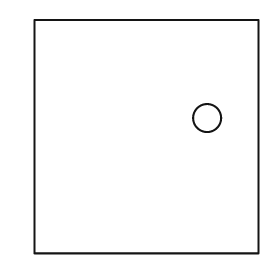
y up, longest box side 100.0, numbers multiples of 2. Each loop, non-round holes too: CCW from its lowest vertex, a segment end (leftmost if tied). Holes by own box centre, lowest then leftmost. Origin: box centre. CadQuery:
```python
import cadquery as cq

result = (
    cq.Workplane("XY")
    .moveTo(-48.0, -50.0)
    .lineTo(48.0, -50.0)
    .lineTo(48.0, 50.0)
    .lineTo(-48.0, 50.0)
    .close()
    .moveTo(26.0, 8.0)
    .circle(6.0)
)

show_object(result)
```